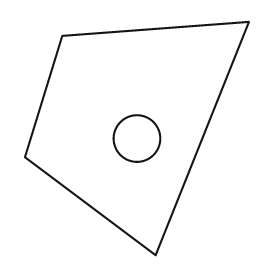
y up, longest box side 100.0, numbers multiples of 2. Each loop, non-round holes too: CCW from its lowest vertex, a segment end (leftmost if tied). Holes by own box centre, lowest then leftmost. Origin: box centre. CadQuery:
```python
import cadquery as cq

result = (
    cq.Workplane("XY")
    .moveTo(8.0, -50.0)
    .lineTo(48.0, 50.0)
    .lineTo(-32.0, 44.0)
    .lineTo(-48.0, -8.0)
    .close()
    .moveTo(0.0, 0.0)
    .circle(10.0)
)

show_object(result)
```